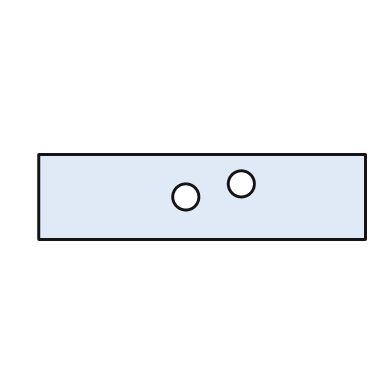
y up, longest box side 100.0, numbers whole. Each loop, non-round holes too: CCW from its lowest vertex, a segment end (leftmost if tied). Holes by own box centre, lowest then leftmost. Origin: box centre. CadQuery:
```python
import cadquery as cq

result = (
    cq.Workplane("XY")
    .moveTo(-50.0, -13.0)
    .lineTo(50.0, -13.0)
    .lineTo(50.0, 13.0)
    .lineTo(-50.0, 13.0)
    .close()
    .moveTo(-5.0, 0.0)
    .circle(4.0)
    .moveTo(12.0, 4.0)
    .circle(4.0)
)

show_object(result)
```